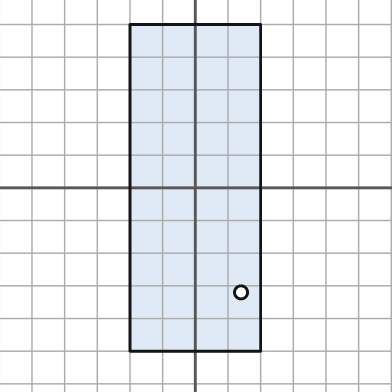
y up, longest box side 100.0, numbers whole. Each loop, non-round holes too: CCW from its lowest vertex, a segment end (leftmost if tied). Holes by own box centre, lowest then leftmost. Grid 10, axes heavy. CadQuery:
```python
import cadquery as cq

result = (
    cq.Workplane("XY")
    .moveTo(-20.0, -50.0)
    .lineTo(20.0, -50.0)
    .lineTo(20.0, 50.0)
    .lineTo(-20.0, 50.0)
    .close()
    .moveTo(14.0, -32.0)
    .circle(2.0)
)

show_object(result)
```